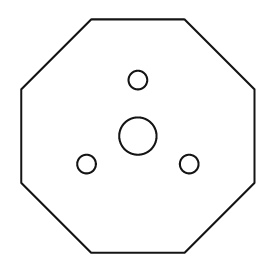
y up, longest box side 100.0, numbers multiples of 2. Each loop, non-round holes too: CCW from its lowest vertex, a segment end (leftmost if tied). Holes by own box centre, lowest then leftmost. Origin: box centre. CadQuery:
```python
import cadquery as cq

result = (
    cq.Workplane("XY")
    .moveTo(-20.0, -50.0)
    .lineTo(20.0, -50.0)
    .lineTo(50.0, -20.0)
    .lineTo(50.0, 20.0)
    .lineTo(20.0, 50.0)
    .lineTo(-20.0, 50.0)
    .lineTo(-50.0, 20.0)
    .lineTo(-50.0, -20.0)
    .close()
    .moveTo(-22.0, -12.0)
    .circle(4.0)
    .moveTo(22.0, -12.0)
    .circle(4.0)
    .moveTo(0.0, 0.0)
    .circle(8.0)
    .moveTo(0.0, 24.0)
    .circle(4.0)
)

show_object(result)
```